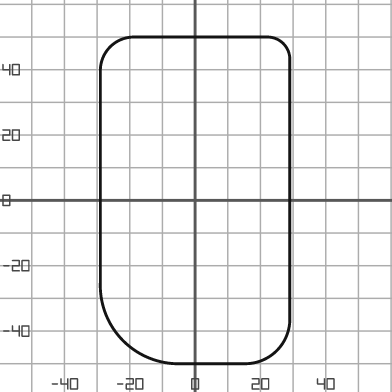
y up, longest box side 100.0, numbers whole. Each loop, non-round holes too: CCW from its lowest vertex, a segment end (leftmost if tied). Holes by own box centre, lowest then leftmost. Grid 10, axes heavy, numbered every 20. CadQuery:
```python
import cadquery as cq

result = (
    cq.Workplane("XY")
    .moveTo(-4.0, -50.0)
    .lineTo(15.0, -50.0)
    .threePointArc((25.0, -46.0), (29.0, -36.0))
    .lineTo(29.0, 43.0)
    .threePointArc((27.0, 48.0), (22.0, 50.0))
    .lineTo(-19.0, 50.0)
    .threePointArc((-26.0, 47.0), (-29.0, 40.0))
    .lineTo(-29.0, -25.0)
    .threePointArc((-22.0, -43.0), (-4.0, -50.0))
    .close()
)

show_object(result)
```